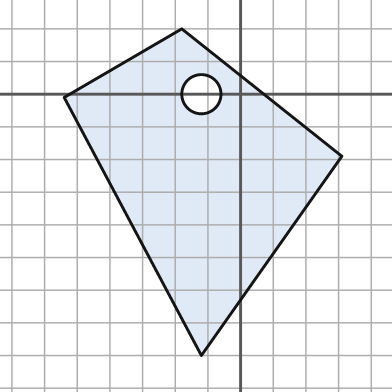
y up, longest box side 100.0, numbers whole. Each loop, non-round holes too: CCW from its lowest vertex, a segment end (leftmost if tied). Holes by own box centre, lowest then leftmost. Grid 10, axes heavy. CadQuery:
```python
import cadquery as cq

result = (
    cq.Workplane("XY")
    .moveTo(-12.0, -80.0)
    .lineTo(31.0, -19.0)
    .lineTo(-18.0, 20.0)
    .lineTo(-54.0, -1.0)
    .close()
    .moveTo(-12.0, 0.0)
    .circle(6.0)
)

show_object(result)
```